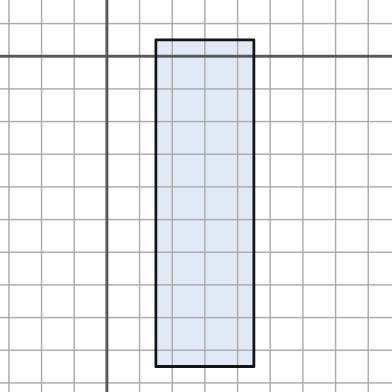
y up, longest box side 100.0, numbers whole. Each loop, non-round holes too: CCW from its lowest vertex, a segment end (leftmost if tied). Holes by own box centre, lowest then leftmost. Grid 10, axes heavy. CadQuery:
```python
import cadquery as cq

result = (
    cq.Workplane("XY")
    .moveTo(15.0, -95.0)
    .lineTo(45.0, -95.0)
    .lineTo(45.0, 5.0)
    .lineTo(15.0, 5.0)
    .close()
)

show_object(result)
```